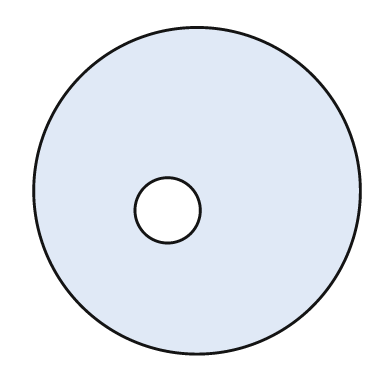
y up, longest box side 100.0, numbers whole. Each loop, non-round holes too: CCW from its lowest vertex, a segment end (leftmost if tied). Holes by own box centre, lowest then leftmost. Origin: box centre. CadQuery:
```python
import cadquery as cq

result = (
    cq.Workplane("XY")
    .moveTo(0.0, 0.0)
    .circle(50.0)
    .moveTo(-9.0, -6.0)
    .circle(10.0)
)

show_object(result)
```